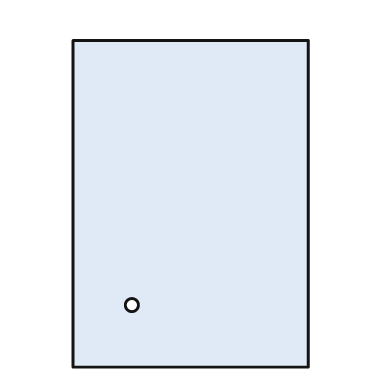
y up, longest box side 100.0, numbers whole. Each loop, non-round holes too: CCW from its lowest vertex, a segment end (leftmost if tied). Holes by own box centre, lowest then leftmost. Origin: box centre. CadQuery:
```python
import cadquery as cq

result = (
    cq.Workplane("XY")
    .moveTo(-36.0, -50.0)
    .lineTo(36.0, -50.0)
    .lineTo(36.0, 50.0)
    .lineTo(-36.0, 50.0)
    .close()
    .moveTo(-18.0, -31.0)
    .circle(2.0)
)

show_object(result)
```